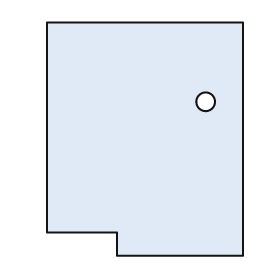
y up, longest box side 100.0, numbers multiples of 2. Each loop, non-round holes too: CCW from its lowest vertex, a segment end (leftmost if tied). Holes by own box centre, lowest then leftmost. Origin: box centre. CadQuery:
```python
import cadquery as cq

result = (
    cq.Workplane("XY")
    .moveTo(-12.0, -50.0)
    .lineTo(42.0, -50.0)
    .lineTo(42.0, 50.0)
    .lineTo(-42.0, 50.0)
    .lineTo(-42.0, -40.0)
    .lineTo(-12.0, -40.0)
    .close()
    .moveTo(26.0, 16.0)
    .circle(4.0)
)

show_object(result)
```